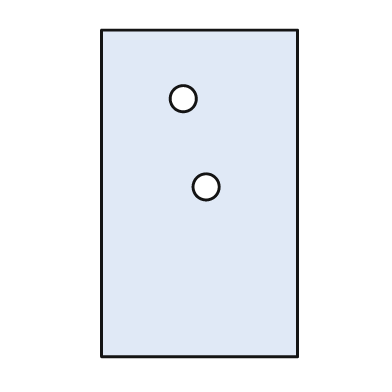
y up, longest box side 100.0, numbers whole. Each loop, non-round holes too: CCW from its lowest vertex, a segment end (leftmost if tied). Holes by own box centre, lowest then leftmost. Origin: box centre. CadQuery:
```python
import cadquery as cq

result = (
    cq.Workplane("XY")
    .moveTo(-30.0, -50.0)
    .lineTo(30.0, -50.0)
    .lineTo(30.0, 50.0)
    .lineTo(-30.0, 50.0)
    .close()
    .moveTo(2.0, 2.0)
    .circle(4.0)
    .moveTo(-5.0, 29.0)
    .circle(4.0)
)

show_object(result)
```